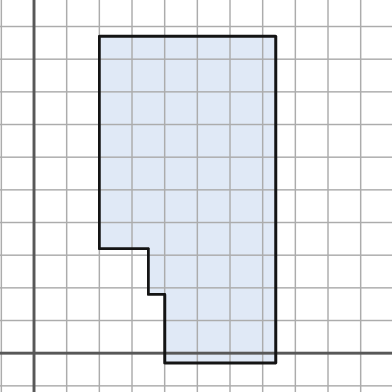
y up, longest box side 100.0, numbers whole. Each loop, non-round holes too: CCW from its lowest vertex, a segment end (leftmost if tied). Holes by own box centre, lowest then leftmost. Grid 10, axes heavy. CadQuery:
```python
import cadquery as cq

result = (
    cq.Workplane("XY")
    .moveTo(40.0, -3.0)
    .lineTo(74.0, -3.0)
    .lineTo(74.0, 97.0)
    .lineTo(20.0, 97.0)
    .lineTo(20.0, 32.0)
    .lineTo(35.0, 32.0)
    .lineTo(35.0, 18.0)
    .lineTo(40.0, 18.0)
    .close()
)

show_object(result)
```